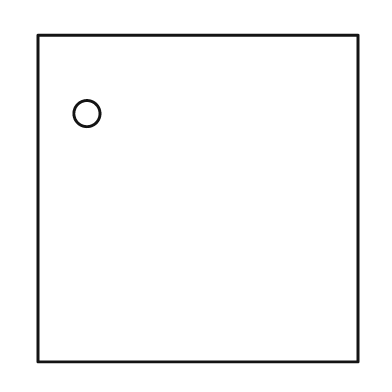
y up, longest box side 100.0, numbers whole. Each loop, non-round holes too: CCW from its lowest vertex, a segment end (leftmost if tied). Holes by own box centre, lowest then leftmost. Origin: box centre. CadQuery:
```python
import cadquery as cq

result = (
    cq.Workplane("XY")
    .moveTo(-49.0, -50.0)
    .lineTo(49.0, -50.0)
    .lineTo(49.0, 50.0)
    .lineTo(-49.0, 50.0)
    .close()
    .moveTo(-34.0, 26.0)
    .circle(4.0)
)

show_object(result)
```